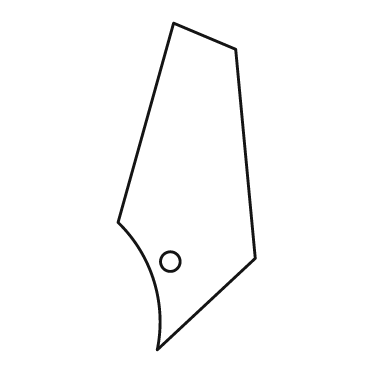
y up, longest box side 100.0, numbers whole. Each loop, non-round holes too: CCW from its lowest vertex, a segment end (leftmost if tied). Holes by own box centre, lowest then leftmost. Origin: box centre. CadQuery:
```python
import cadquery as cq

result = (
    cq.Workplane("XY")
    .moveTo(-9.0, -50.0)
    .lineTo(21.0, -22.0)
    .lineTo(15.0, 42.0)
    .lineTo(-4.0, 50.0)
    .lineTo(-21.0, -11.0)
    .threePointArc((-10.0, -29.0), (-9.0, -50.0))
    .close()
    .moveTo(-5.0, -23.0)
    .circle(3.0)
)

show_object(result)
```